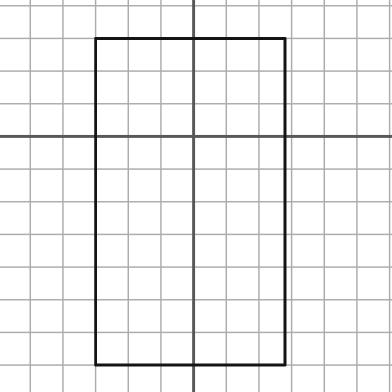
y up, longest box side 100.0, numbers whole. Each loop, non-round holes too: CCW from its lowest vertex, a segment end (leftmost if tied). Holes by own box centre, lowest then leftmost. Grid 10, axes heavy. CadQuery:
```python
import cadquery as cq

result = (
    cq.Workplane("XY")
    .moveTo(-30.0, -70.0)
    .lineTo(28.0, -70.0)
    .lineTo(28.0, 30.0)
    .lineTo(-30.0, 30.0)
    .close()
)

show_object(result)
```